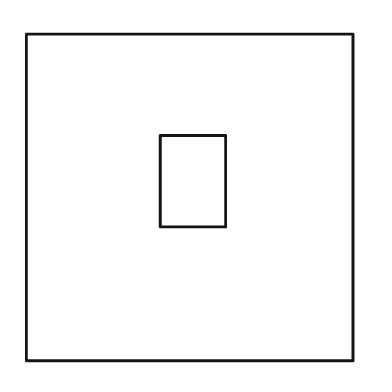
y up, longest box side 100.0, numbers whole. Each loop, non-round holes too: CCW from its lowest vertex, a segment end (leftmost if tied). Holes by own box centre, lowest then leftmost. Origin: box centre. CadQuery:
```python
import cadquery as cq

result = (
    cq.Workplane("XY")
    .moveTo(-50.0, -50.0)
    .lineTo(50.0, -50.0)
    .lineTo(50.0, 50.0)
    .lineTo(-50.0, 50.0)
    .close()
    .moveTo(-9.0, -9.0)
    .lineTo(11.0, -9.0)
    .lineTo(11.0, 19.0)
    .lineTo(-9.0, 19.0)
    .close()
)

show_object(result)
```